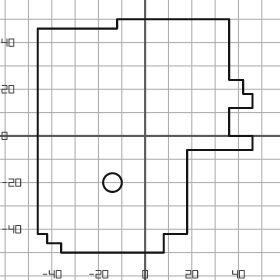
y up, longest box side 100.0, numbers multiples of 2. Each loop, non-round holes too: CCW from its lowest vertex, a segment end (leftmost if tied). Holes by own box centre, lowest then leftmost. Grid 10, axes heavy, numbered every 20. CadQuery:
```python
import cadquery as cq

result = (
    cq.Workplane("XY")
    .moveTo(-36.0, -50.0)
    .lineTo(8.0, -50.0)
    .lineTo(8.0, -42.0)
    .lineTo(18.0, -42.0)
    .lineTo(18.0, -6.0)
    .lineTo(46.0, -6.0)
    .lineTo(46.0, 0.0)
    .lineTo(36.0, 0.0)
    .lineTo(36.0, 12.0)
    .lineTo(46.0, 12.0)
    .lineTo(46.0, 18.0)
    .lineTo(42.0, 18.0)
    .lineTo(42.0, 24.0)
    .lineTo(36.0, 24.0)
    .lineTo(36.0, 50.0)
    .lineTo(-12.0, 50.0)
    .lineTo(-12.0, 46.0)
    .lineTo(-46.0, 46.0)
    .lineTo(-46.0, -42.0)
    .lineTo(-42.0, -42.0)
    .lineTo(-42.0, -46.0)
    .lineTo(-36.0, -46.0)
    .close()
    .moveTo(-14.0, -20.0)
    .circle(4.0)
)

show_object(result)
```